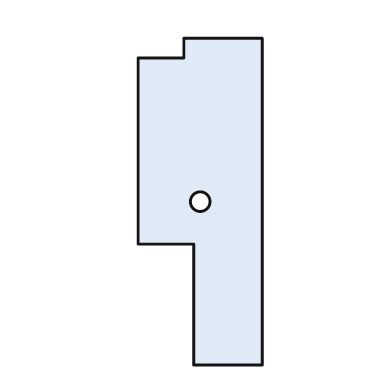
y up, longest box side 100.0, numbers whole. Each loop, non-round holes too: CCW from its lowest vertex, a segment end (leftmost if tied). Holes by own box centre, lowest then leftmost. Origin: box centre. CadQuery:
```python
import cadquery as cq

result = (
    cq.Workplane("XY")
    .moveTo(-2.0, -50.0)
    .lineTo(19.0, -50.0)
    .lineTo(19.0, 50.0)
    .lineTo(-5.0, 50.0)
    .lineTo(-5.0, 44.0)
    .lineTo(-19.0, 44.0)
    .lineTo(-19.0, -13.0)
    .lineTo(-2.0, -13.0)
    .close()
    .moveTo(0.0, 0.0)
    .circle(3.0)
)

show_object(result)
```